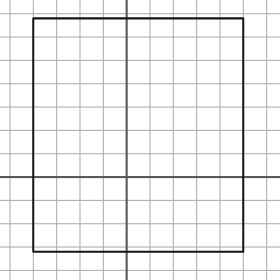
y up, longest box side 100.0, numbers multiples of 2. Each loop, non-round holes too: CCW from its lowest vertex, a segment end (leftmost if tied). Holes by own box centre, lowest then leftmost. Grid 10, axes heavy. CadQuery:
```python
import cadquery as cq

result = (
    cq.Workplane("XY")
    .moveTo(-40.0, -32.0)
    .lineTo(50.0, -32.0)
    .lineTo(50.0, 68.0)
    .lineTo(-40.0, 68.0)
    .close()
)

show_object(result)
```